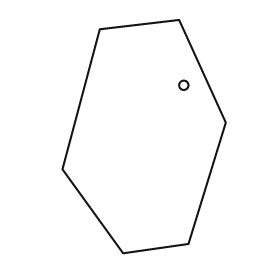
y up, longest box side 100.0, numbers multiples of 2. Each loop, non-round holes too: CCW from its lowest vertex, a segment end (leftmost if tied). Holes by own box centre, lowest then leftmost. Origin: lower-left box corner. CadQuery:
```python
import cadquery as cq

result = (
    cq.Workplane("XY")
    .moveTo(26.0, 0.0)
    .lineTo(54.0, 4.0)
    .lineTo(70.0, 56.0)
    .lineTo(50.0, 100.0)
    .lineTo(16.0, 96.0)
    .lineTo(0.0, 36.0)
    .close()
    .moveTo(52.0, 72.0)
    .circle(2.0)
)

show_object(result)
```